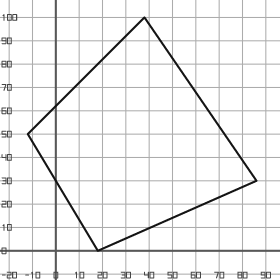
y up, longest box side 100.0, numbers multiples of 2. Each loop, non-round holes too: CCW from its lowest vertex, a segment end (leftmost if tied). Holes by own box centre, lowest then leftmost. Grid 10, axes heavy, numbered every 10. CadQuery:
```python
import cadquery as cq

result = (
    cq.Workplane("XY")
    .moveTo(18.0, 0.0)
    .lineTo(86.0, 30.0)
    .lineTo(38.0, 100.0)
    .lineTo(-12.0, 50.0)
    .close()
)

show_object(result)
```